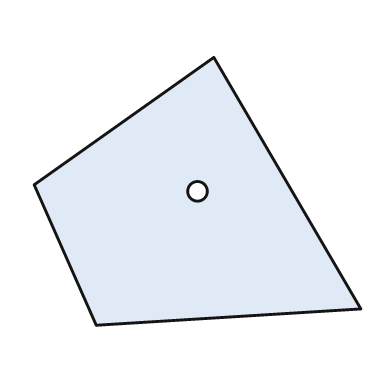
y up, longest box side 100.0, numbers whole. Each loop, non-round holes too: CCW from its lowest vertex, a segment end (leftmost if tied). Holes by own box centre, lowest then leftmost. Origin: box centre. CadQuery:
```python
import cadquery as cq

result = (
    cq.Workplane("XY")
    .moveTo(-31.0, -41.0)
    .lineTo(50.0, -36.0)
    .lineTo(5.0, 41.0)
    .lineTo(-50.0, 2.0)
    .close()
    .moveTo(0.0, 0.0)
    .circle(3.0)
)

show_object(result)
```